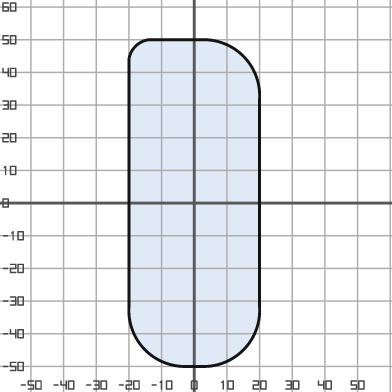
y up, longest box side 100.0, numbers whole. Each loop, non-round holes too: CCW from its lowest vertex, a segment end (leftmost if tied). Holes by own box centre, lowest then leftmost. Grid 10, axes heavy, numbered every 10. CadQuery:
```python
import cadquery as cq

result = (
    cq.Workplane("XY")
    .moveTo(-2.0, -50.0)
    .lineTo(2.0, -50.0)
    .threePointArc((15.0, -45.0), (20.0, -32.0))
    .lineTo(20.0, 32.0)
    .threePointArc((15.0, 45.0), (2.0, 50.0))
    .lineTo(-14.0, 50.0)
    .threePointArc((-18.0, 48.0), (-20.0, 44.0))
    .lineTo(-20.0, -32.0)
    .threePointArc((-15.0, -45.0), (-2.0, -50.0))
    .close()
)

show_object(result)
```